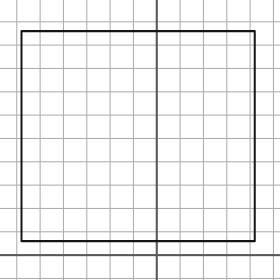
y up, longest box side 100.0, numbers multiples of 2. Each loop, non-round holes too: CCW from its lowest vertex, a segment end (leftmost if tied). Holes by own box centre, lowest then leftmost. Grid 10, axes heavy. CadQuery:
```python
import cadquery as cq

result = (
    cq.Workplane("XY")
    .moveTo(-58.0, 6.0)
    .lineTo(42.0, 6.0)
    .lineTo(42.0, 96.0)
    .lineTo(-58.0, 96.0)
    .close()
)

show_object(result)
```